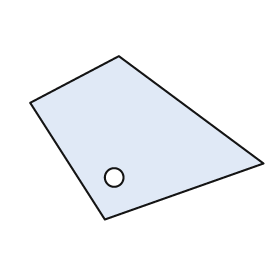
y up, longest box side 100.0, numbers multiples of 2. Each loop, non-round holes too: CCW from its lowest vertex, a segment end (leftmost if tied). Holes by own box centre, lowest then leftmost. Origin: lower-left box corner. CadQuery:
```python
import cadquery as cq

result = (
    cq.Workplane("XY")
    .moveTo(32.0, 0.0)
    .lineTo(100.0, 24.0)
    .lineTo(38.0, 70.0)
    .lineTo(0.0, 50.0)
    .close()
    .moveTo(36.0, 18.0)
    .circle(4.0)
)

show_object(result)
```